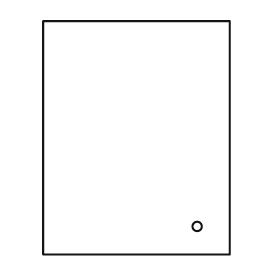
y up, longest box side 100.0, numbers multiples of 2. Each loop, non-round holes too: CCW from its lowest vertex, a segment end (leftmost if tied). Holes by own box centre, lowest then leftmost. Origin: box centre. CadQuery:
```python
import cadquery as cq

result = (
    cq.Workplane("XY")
    .moveTo(-40.0, -50.0)
    .lineTo(40.0, -50.0)
    .lineTo(40.0, 50.0)
    .lineTo(-40.0, 50.0)
    .close()
    .moveTo(26.0, -38.0)
    .circle(2.0)
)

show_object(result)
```